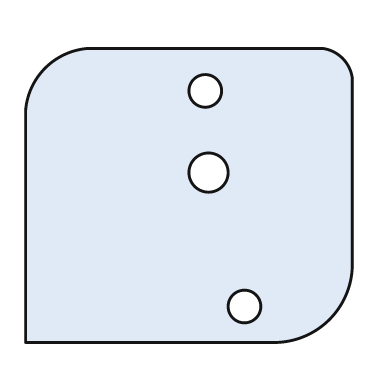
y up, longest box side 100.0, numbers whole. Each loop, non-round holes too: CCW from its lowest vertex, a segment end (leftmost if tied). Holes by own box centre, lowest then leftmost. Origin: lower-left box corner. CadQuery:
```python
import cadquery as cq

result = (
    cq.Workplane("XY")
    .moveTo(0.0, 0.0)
    .lineTo(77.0, 0.0)
    .threePointArc((93.0, 7.0), (100.0, 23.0))
    .lineTo(100.0, 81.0)
    .threePointArc((97.0, 87.0), (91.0, 90.0))
    .lineTo(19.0, 90.0)
    .threePointArc((6.0, 84.0), (0.0, 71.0))
    .close()
    .moveTo(67.0, 11.0)
    .circle(5.0)
    .moveTo(56.0, 52.0)
    .circle(6.0)
    .moveTo(55.0, 77.0)
    .circle(5.0)
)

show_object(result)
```